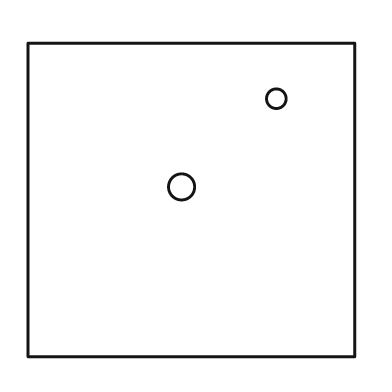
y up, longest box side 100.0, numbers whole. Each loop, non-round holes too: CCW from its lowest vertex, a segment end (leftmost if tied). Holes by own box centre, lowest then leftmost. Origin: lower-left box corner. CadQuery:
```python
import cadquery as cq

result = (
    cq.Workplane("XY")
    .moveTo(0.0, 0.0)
    .lineTo(100.0, 0.0)
    .lineTo(100.0, 96.0)
    .lineTo(0.0, 96.0)
    .close()
    .moveTo(47.0, 52.0)
    .circle(4.0)
    .moveTo(76.0, 79.0)
    .circle(3.0)
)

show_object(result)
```